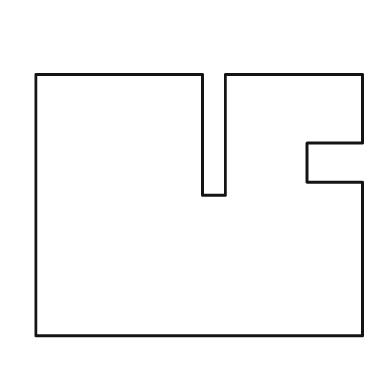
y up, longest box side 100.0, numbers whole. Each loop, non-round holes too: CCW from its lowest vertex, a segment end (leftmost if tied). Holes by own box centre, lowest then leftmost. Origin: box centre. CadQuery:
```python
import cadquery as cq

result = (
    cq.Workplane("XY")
    .moveTo(-50.0, -40.0)
    .lineTo(50.0, -40.0)
    .lineTo(50.0, 7.0)
    .lineTo(33.0, 7.0)
    .lineTo(33.0, 19.0)
    .lineTo(50.0, 19.0)
    .lineTo(50.0, 40.0)
    .lineTo(8.0, 40.0)
    .lineTo(8.0, 3.0)
    .lineTo(1.0, 3.0)
    .lineTo(1.0, 40.0)
    .lineTo(-50.0, 40.0)
    .close()
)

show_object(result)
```